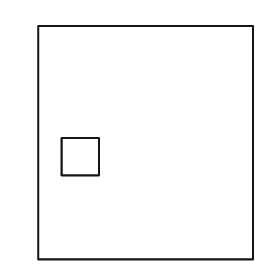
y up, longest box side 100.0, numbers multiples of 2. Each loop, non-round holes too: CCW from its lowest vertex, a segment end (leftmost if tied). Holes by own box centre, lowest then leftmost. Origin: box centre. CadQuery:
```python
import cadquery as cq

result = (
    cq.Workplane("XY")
    .moveTo(-46.0, -50.0)
    .lineTo(46.0, -50.0)
    .lineTo(46.0, 50.0)
    .lineTo(-46.0, 50.0)
    .close()
    .moveTo(-36.0, -14.0)
    .lineTo(-20.0, -14.0)
    .lineTo(-20.0, 2.0)
    .lineTo(-36.0, 2.0)
    .close()
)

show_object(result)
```